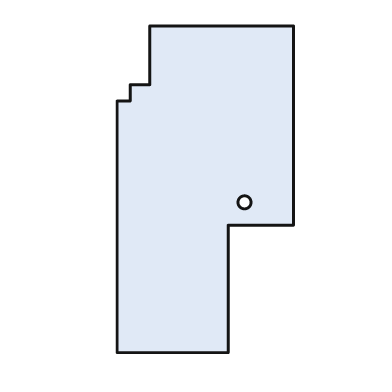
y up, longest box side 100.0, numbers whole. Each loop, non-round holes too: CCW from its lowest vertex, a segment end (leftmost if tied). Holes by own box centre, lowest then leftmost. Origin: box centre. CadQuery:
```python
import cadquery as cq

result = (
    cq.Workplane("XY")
    .moveTo(-27.0, -50.0)
    .lineTo(7.0, -50.0)
    .lineTo(7.0, -11.0)
    .lineTo(27.0, -11.0)
    .lineTo(27.0, 50.0)
    .lineTo(-17.0, 50.0)
    .lineTo(-17.0, 32.0)
    .lineTo(-23.0, 32.0)
    .lineTo(-23.0, 27.0)
    .lineTo(-27.0, 27.0)
    .close()
    .moveTo(12.0, -4.0)
    .circle(2.0)
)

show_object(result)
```